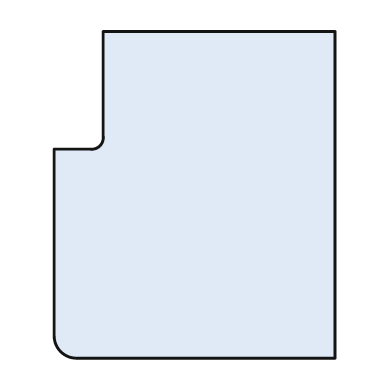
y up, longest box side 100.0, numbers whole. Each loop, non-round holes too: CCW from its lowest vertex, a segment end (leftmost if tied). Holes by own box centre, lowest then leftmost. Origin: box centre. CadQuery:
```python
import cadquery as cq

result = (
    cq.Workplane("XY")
    .moveTo(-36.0, -50.0)
    .lineTo(43.0, -50.0)
    .lineTo(43.0, 50.0)
    .lineTo(-28.0, 50.0)
    .lineTo(-28.0, 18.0)
    .threePointArc((-29.0, 15.0), (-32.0, 14.0))
    .lineTo(-43.0, 14.0)
    .lineTo(-43.0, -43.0)
    .threePointArc((-41.0, -48.0), (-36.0, -50.0))
    .close()
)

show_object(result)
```